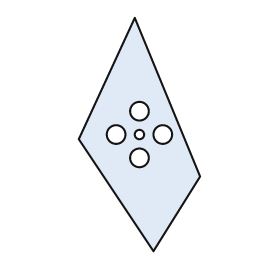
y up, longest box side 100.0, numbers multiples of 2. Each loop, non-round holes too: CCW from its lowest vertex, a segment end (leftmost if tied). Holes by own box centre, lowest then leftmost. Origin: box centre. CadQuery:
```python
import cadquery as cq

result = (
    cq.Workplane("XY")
    .moveTo(6.0, -50.0)
    .lineTo(26.0, -18.0)
    .lineTo(-2.0, 50.0)
    .lineTo(-26.0, -2.0)
    .close()
    .moveTo(0.0, -10.0)
    .circle(4.0)
    .moveTo(-10.0, 0.0)
    .circle(4.0)
    .moveTo(0.0, 0.0)
    .circle(2.0)
    .moveTo(10.0, 0.0)
    .circle(4.0)
    .moveTo(0.0, 10.0)
    .circle(4.0)
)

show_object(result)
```